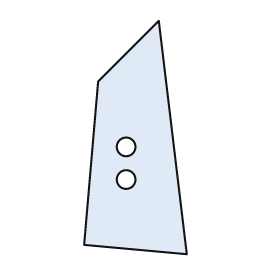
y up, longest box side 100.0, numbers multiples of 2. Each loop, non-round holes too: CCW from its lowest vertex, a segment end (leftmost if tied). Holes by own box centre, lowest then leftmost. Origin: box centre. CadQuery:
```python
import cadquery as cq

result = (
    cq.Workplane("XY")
    .moveTo(22.0, -50.0)
    .lineTo(10.0, 50.0)
    .lineTo(-16.0, 24.0)
    .lineTo(-22.0, -46.0)
    .close()
    .moveTo(-4.0, -18.0)
    .circle(4.0)
    .moveTo(-4.0, -4.0)
    .circle(4.0)
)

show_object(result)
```